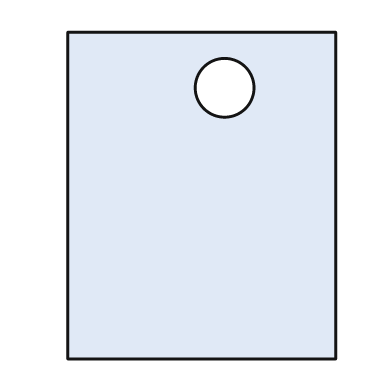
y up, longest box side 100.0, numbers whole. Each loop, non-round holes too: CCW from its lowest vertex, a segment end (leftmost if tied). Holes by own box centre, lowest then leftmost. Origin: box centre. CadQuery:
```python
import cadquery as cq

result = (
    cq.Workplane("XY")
    .moveTo(-41.0, -50.0)
    .lineTo(41.0, -50.0)
    .lineTo(41.0, 50.0)
    .lineTo(-41.0, 50.0)
    .close()
    .moveTo(7.0, 33.0)
    .circle(9.0)
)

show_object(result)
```